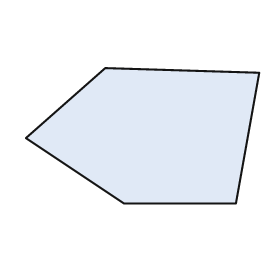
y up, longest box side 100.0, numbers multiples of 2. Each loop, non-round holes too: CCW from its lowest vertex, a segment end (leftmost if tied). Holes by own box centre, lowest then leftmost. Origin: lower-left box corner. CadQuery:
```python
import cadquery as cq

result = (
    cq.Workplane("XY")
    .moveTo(42.0, 0.0)
    .lineTo(90.0, 0.0)
    .lineTo(100.0, 56.0)
    .lineTo(34.0, 58.0)
    .lineTo(0.0, 28.0)
    .close()
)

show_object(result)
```